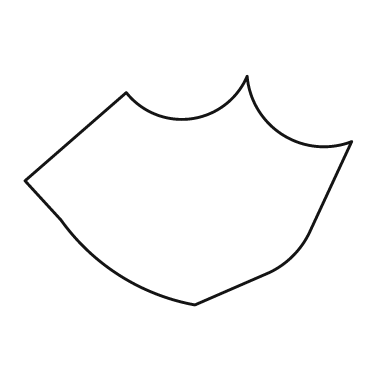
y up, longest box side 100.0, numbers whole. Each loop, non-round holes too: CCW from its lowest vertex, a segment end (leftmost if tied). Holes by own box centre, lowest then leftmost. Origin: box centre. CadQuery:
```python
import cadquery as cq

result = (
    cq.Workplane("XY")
    .moveTo(2.0, -35.0)
    .lineTo(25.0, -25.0)
    .threePointArc((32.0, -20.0), (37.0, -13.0))
    .lineTo(50.0, 15.0)
    .threePointArc((29.0, 17.0), (18.0, 35.0))
    .threePointArc((1.0, 22.0), (-19.0, 30.0))
    .lineTo(-50.0, 3.0)
    .lineTo(-39.0, -9.0)
    .threePointArc((-21.0, -26.0), (2.0, -35.0))
    .close()
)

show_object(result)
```